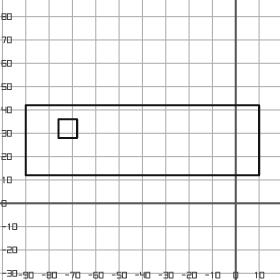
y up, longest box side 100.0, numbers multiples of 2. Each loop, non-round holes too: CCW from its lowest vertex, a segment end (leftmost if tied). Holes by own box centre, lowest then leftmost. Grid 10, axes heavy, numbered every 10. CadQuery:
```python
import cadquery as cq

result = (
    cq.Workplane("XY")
    .moveTo(-90.0, 12.0)
    .lineTo(10.0, 12.0)
    .lineTo(10.0, 42.0)
    .lineTo(-90.0, 42.0)
    .close()
    .moveTo(-76.0, 28.0)
    .lineTo(-68.0, 28.0)
    .lineTo(-68.0, 36.0)
    .lineTo(-76.0, 36.0)
    .close()
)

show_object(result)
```